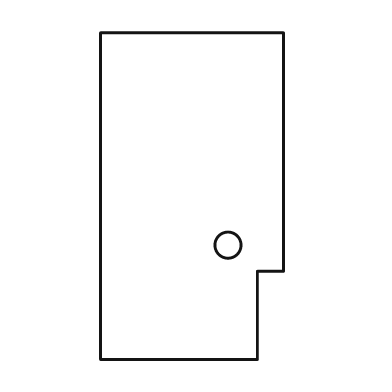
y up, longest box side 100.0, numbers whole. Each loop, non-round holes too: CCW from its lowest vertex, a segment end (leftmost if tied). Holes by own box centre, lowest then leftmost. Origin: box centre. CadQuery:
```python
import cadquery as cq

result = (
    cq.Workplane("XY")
    .moveTo(-28.0, -50.0)
    .lineTo(20.0, -50.0)
    .lineTo(20.0, -23.0)
    .lineTo(28.0, -23.0)
    .lineTo(28.0, 50.0)
    .lineTo(-28.0, 50.0)
    .close()
    .moveTo(11.0, -15.0)
    .circle(4.0)
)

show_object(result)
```